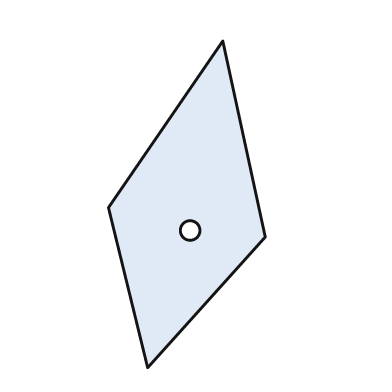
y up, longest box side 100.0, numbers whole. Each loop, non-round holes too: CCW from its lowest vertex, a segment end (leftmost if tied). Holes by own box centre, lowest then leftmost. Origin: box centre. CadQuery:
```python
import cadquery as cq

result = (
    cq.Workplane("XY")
    .moveTo(-12.0, -50.0)
    .lineTo(24.0, -10.0)
    .lineTo(11.0, 50.0)
    .lineTo(-24.0, -1.0)
    .close()
    .moveTo(1.0, -8.0)
    .circle(3.0)
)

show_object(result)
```